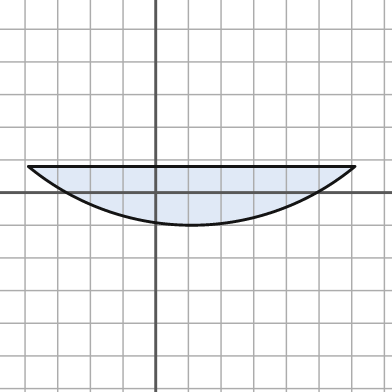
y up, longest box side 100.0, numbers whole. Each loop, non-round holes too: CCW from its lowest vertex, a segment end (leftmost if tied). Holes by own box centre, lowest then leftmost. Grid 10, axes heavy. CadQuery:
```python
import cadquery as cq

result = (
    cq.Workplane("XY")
    .moveTo(-39.0, 8.0)
    .threePointArc((11.0, -10.0), (61.0, 8.0))
    .close()
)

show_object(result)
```